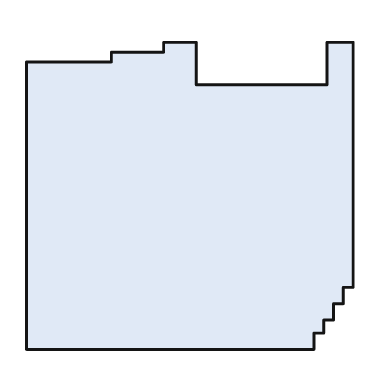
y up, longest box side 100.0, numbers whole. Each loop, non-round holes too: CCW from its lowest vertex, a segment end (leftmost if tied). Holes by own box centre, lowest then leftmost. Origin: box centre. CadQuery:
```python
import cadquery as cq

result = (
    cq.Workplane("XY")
    .moveTo(-50.0, -47.0)
    .lineTo(38.0, -47.0)
    .lineTo(38.0, -42.0)
    .lineTo(41.0, -42.0)
    .lineTo(41.0, -38.0)
    .lineTo(44.0, -38.0)
    .lineTo(44.0, -33.0)
    .lineTo(47.0, -33.0)
    .lineTo(47.0, -28.0)
    .lineTo(50.0, -28.0)
    .lineTo(50.0, 47.0)
    .lineTo(42.0, 47.0)
    .lineTo(42.0, 34.0)
    .lineTo(2.0, 34.0)
    .lineTo(2.0, 47.0)
    .lineTo(-8.0, 47.0)
    .lineTo(-8.0, 44.0)
    .lineTo(-24.0, 44.0)
    .lineTo(-24.0, 41.0)
    .lineTo(-50.0, 41.0)
    .close()
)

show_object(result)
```